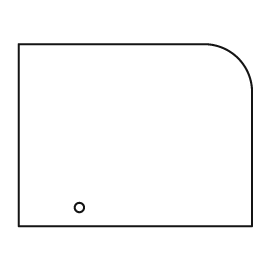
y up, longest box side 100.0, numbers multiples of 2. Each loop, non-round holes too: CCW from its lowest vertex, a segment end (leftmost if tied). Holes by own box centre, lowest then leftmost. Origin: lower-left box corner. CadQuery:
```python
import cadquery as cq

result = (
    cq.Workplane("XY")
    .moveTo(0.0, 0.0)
    .lineTo(100.0, 0.0)
    .lineTo(100.0, 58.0)
    .threePointArc((94.0, 72.0), (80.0, 78.0))
    .lineTo(0.0, 78.0)
    .close()
    .moveTo(26.0, 8.0)
    .circle(2.0)
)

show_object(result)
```